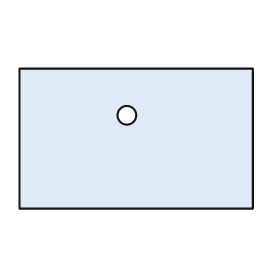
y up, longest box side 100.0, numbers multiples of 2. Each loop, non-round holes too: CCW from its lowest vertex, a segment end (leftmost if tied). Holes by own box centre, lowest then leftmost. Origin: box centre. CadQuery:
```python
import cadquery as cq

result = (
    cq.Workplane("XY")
    .moveTo(-50.0, -30.0)
    .lineTo(50.0, -30.0)
    .lineTo(50.0, 30.0)
    .lineTo(-50.0, 30.0)
    .close()
    .moveTo(-4.0, 10.0)
    .circle(4.0)
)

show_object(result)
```